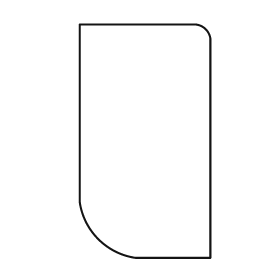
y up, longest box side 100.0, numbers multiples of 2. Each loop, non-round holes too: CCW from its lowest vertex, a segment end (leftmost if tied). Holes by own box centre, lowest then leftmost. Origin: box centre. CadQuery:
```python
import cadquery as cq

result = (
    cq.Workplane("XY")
    .moveTo(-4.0, -50.0)
    .lineTo(28.0, -50.0)
    .lineTo(28.0, 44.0)
    .threePointArc((26.0, 48.0), (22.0, 50.0))
    .lineTo(-28.0, 50.0)
    .lineTo(-28.0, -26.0)
    .threePointArc((-20.0, -42.0), (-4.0, -50.0))
    .close()
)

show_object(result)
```